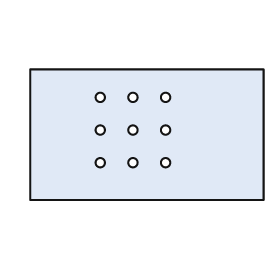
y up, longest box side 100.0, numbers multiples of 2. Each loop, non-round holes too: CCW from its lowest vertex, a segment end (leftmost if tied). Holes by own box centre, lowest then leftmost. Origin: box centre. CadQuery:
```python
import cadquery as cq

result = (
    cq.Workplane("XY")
    .moveTo(-50.0, -28.0)
    .lineTo(50.0, -28.0)
    .lineTo(50.0, 28.0)
    .lineTo(-50.0, 28.0)
    .close()
    .moveTo(-20.0, -12.0)
    .circle(2.0)
    .moveTo(-6.0, -12.0)
    .circle(2.0)
    .moveTo(8.0, -12.0)
    .circle(2.0)
    .moveTo(-20.0, 2.0)
    .circle(2.0)
    .moveTo(-6.0, 2.0)
    .circle(2.0)
    .moveTo(8.0, 2.0)
    .circle(2.0)
    .moveTo(-20.0, 16.0)
    .circle(2.0)
    .moveTo(-6.0, 16.0)
    .circle(2.0)
    .moveTo(8.0, 16.0)
    .circle(2.0)
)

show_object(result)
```